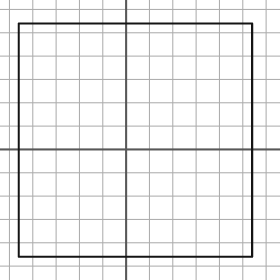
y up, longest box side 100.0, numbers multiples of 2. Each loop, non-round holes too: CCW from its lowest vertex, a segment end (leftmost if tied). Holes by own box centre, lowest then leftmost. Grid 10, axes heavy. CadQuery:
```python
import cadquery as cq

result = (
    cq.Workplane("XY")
    .moveTo(-46.0, -46.0)
    .lineTo(54.0, -46.0)
    .lineTo(54.0, 54.0)
    .lineTo(-46.0, 54.0)
    .close()
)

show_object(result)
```